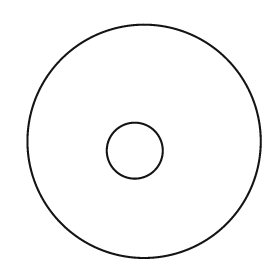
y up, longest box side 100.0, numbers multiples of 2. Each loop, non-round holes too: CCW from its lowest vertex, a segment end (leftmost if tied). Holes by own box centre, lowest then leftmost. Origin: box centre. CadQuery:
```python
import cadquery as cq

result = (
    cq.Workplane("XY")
    .moveTo(0.0, 0.0)
    .circle(50.0)
    .moveTo(-4.0, -4.0)
    .circle(12.0)
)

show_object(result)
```